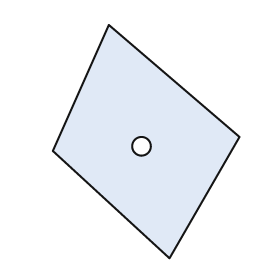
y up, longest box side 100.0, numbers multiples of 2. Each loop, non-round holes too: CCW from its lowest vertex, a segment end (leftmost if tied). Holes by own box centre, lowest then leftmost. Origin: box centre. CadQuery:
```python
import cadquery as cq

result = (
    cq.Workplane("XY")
    .moveTo(10.0, -50.0)
    .lineTo(40.0, 2.0)
    .lineTo(-16.0, 50.0)
    .lineTo(-40.0, -4.0)
    .close()
    .moveTo(-2.0, -2.0)
    .circle(4.0)
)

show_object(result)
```